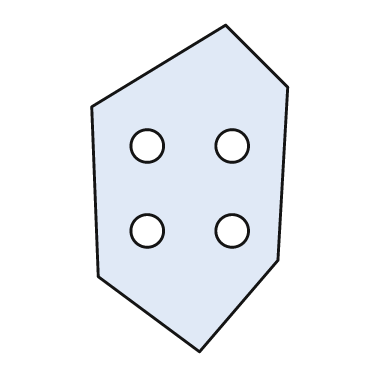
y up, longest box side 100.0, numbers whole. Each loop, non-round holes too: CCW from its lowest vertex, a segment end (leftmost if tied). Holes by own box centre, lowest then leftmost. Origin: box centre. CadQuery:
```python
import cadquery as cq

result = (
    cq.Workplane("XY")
    .moveTo(3.0, -50.0)
    .lineTo(27.0, -22.0)
    .lineTo(30.0, 31.0)
    .lineTo(11.0, 50.0)
    .lineTo(-30.0, 25.0)
    .lineTo(-28.0, -27.0)
    .close()
    .moveTo(-13.0, -13.0)
    .circle(5.0)
    .moveTo(13.0, -13.0)
    .circle(5.0)
    .moveTo(-13.0, 13.0)
    .circle(5.0)
    .moveTo(13.0, 13.0)
    .circle(5.0)
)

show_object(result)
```